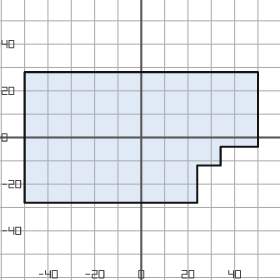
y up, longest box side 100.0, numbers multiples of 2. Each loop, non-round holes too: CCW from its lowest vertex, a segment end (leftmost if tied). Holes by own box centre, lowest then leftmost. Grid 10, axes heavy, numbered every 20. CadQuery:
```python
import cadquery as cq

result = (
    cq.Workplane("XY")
    .moveTo(-50.0, -28.0)
    .lineTo(24.0, -28.0)
    .lineTo(24.0, -12.0)
    .lineTo(34.0, -12.0)
    .lineTo(34.0, -4.0)
    .lineTo(50.0, -4.0)
    .lineTo(50.0, 28.0)
    .lineTo(-50.0, 28.0)
    .close()
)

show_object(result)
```